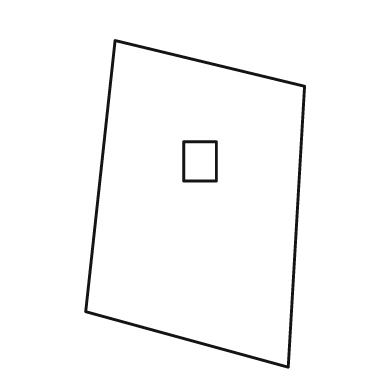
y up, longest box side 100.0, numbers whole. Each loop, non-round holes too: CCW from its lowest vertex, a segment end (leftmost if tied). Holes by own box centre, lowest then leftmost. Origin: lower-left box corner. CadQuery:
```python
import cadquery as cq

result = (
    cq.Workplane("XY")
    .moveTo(62.0, 0.0)
    .lineTo(67.0, 86.0)
    .lineTo(9.0, 100.0)
    .lineTo(0.0, 17.0)
    .close()
    .moveTo(30.0, 57.0)
    .lineTo(40.0, 57.0)
    .lineTo(40.0, 69.0)
    .lineTo(30.0, 69.0)
    .close()
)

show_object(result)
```